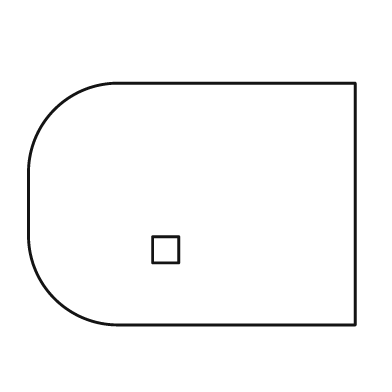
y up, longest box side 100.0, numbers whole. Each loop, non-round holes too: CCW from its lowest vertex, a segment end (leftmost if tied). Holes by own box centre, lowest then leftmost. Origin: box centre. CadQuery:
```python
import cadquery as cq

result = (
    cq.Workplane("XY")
    .moveTo(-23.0, -37.0)
    .lineTo(50.0, -37.0)
    .lineTo(50.0, 37.0)
    .lineTo(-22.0, 37.0)
    .threePointArc((-42.0, 29.0), (-50.0, 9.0))
    .lineTo(-50.0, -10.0)
    .threePointArc((-42.0, -29.0), (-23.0, -37.0))
    .close()
    .moveTo(-12.0, -18.0)
    .lineTo(-4.0, -18.0)
    .lineTo(-4.0, -10.0)
    .lineTo(-12.0, -10.0)
    .close()
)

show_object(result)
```